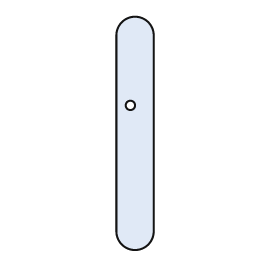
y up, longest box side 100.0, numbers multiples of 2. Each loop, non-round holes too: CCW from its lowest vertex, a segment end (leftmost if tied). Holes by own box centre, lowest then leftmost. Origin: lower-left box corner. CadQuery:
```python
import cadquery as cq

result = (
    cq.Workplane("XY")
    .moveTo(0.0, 8.0)
    .threePointArc((8.0, 0.0), (16.0, 8.0))
    .lineTo(16.0, 92.0)
    .threePointArc((8.0, 100.0), (0.0, 92.0))
    .close()
    .moveTo(6.0, 62.0)
    .circle(2.0)
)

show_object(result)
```